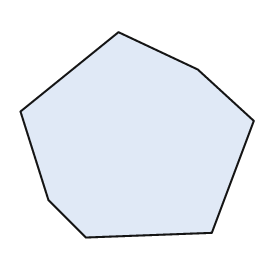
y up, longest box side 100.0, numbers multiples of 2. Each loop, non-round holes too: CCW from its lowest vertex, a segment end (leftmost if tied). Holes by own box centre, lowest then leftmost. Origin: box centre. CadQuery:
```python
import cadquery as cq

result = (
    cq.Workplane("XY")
    .moveTo(-22.0, -44.0)
    .lineTo(32.0, -42.0)
    .lineTo(50.0, 6.0)
    .lineTo(26.0, 28.0)
    .lineTo(-8.0, 44.0)
    .lineTo(-50.0, 10.0)
    .lineTo(-38.0, -28.0)
    .close()
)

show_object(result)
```